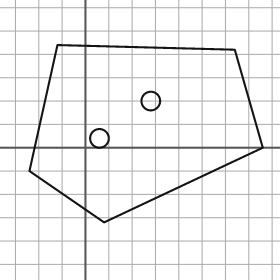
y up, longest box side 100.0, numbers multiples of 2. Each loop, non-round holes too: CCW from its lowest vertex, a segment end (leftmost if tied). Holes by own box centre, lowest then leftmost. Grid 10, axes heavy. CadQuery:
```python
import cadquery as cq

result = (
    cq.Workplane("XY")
    .moveTo(8.0, -32.0)
    .lineTo(76.0, 0.0)
    .lineTo(64.0, 42.0)
    .lineTo(-12.0, 44.0)
    .lineTo(-24.0, -10.0)
    .close()
    .moveTo(6.0, 4.0)
    .circle(4.0)
    .moveTo(28.0, 20.0)
    .circle(4.0)
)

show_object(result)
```